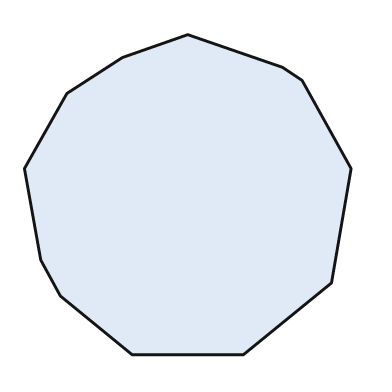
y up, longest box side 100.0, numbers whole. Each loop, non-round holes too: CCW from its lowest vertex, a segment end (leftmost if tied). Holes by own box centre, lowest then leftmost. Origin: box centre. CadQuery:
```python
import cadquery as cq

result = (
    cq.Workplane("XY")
    .moveTo(-17.0, -49.0)
    .lineTo(17.0, -49.0)
    .lineTo(44.0, -27.0)
    .lineTo(50.0, 8.0)
    .lineTo(35.0, 35.0)
    .lineTo(29.0, 39.0)
    .lineTo(0.0, 49.0)
    .lineTo(-20.0, 42.0)
    .lineTo(-37.0, 31.0)
    .lineTo(-50.0, 8.0)
    .lineTo(-45.0, -20.0)
    .lineTo(-39.0, -31.0)
    .close()
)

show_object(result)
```